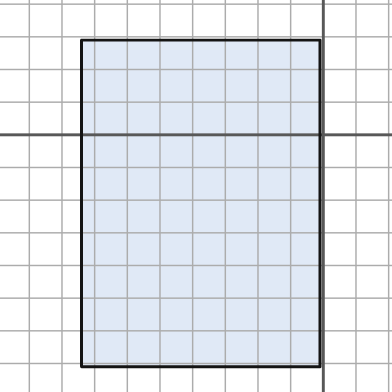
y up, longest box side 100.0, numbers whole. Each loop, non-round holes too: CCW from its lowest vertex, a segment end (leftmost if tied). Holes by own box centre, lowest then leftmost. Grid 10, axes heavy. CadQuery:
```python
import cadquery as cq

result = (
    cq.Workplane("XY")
    .moveTo(-74.0, -71.0)
    .lineTo(-1.0, -71.0)
    .lineTo(-1.0, 29.0)
    .lineTo(-74.0, 29.0)
    .close()
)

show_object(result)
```